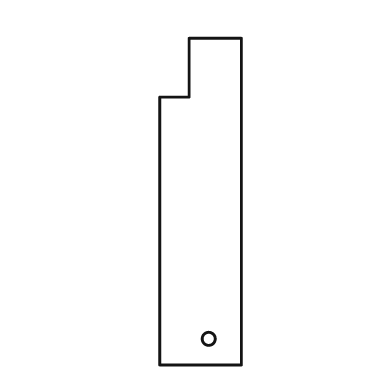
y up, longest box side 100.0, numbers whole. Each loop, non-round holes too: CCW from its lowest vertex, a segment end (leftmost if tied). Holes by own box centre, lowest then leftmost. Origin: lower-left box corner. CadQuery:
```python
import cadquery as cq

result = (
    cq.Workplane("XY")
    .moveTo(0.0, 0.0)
    .lineTo(25.0, 0.0)
    .lineTo(25.0, 100.0)
    .lineTo(9.0, 100.0)
    .lineTo(9.0, 82.0)
    .lineTo(0.0, 82.0)
    .close()
    .moveTo(15.0, 8.0)
    .circle(2.0)
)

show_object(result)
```